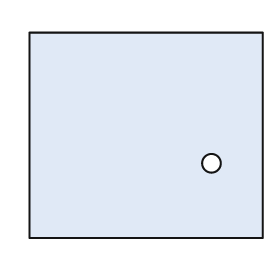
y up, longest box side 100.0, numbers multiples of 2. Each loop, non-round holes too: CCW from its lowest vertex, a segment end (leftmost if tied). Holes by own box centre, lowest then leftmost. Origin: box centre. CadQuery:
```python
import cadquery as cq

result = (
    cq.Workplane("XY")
    .moveTo(-50.0, -44.0)
    .lineTo(50.0, -44.0)
    .lineTo(50.0, 44.0)
    .lineTo(-50.0, 44.0)
    .close()
    .moveTo(28.0, -12.0)
    .circle(4.0)
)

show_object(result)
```